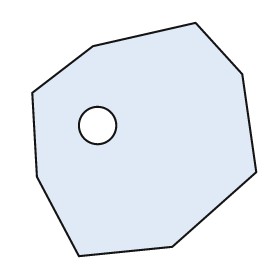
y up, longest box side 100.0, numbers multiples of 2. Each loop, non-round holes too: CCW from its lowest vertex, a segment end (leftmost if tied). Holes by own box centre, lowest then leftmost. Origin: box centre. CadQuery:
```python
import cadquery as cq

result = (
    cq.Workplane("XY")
    .moveTo(-28.0, -50.0)
    .lineTo(12.0, -46.0)
    .lineTo(48.0, -14.0)
    .lineTo(42.0, 28.0)
    .lineTo(22.0, 50.0)
    .lineTo(-22.0, 40.0)
    .lineTo(-48.0, 20.0)
    .lineTo(-46.0, -16.0)
    .close()
    .moveTo(-20.0, 6.0)
    .circle(8.0)
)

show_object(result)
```